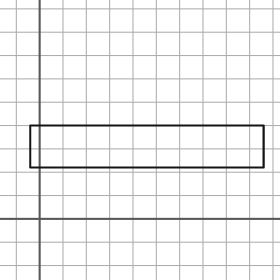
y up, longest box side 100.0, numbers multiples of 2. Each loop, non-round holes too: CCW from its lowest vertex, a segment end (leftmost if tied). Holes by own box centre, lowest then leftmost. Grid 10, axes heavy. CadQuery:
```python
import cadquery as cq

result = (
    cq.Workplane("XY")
    .moveTo(-4.0, 22.0)
    .lineTo(96.0, 22.0)
    .lineTo(96.0, 40.0)
    .lineTo(-4.0, 40.0)
    .close()
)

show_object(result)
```